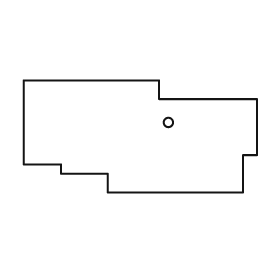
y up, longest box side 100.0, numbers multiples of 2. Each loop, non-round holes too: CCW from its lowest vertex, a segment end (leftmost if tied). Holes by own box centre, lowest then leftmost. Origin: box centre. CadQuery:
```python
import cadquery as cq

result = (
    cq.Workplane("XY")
    .moveTo(-14.0, -24.0)
    .lineTo(44.0, -24.0)
    .lineTo(44.0, -8.0)
    .lineTo(50.0, -8.0)
    .lineTo(50.0, 16.0)
    .lineTo(8.0, 16.0)
    .lineTo(8.0, 24.0)
    .lineTo(-50.0, 24.0)
    .lineTo(-50.0, -12.0)
    .lineTo(-34.0, -12.0)
    .lineTo(-34.0, -16.0)
    .lineTo(-14.0, -16.0)
    .close()
    .moveTo(12.0, 6.0)
    .circle(2.0)
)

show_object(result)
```